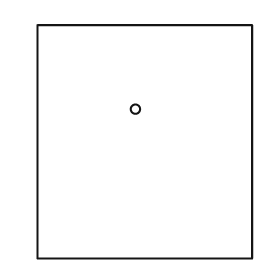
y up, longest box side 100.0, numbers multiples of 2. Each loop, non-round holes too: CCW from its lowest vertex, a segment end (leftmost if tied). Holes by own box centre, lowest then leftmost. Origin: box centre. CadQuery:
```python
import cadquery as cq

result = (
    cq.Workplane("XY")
    .moveTo(-46.0, -50.0)
    .lineTo(46.0, -50.0)
    .lineTo(46.0, 50.0)
    .lineTo(-46.0, 50.0)
    .close()
    .moveTo(-4.0, 14.0)
    .circle(2.0)
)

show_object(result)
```